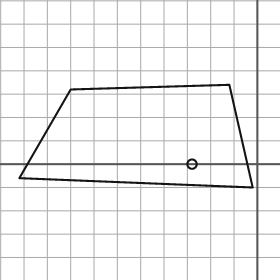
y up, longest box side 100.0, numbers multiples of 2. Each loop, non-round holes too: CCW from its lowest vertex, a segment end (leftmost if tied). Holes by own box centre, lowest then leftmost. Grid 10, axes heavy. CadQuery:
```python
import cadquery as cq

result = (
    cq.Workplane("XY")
    .moveTo(-2.0, -10.0)
    .lineTo(-12.0, 34.0)
    .lineTo(-80.0, 32.0)
    .lineTo(-102.0, -6.0)
    .close()
    .moveTo(-28.0, 0.0)
    .circle(2.0)
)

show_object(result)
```